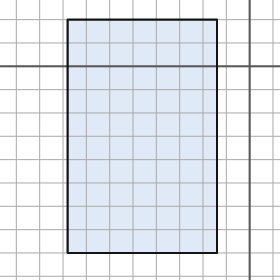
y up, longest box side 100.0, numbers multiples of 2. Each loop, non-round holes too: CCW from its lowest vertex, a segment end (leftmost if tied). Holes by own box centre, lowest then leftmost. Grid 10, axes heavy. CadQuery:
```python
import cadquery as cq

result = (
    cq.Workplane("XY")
    .moveTo(-78.0, -80.0)
    .lineTo(-14.0, -80.0)
    .lineTo(-14.0, 20.0)
    .lineTo(-78.0, 20.0)
    .close()
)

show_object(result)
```